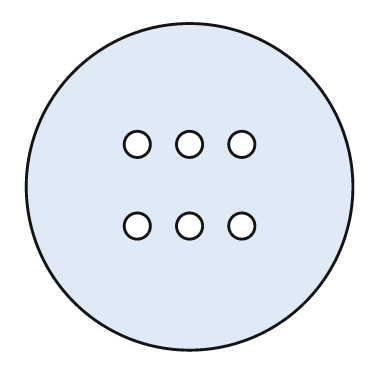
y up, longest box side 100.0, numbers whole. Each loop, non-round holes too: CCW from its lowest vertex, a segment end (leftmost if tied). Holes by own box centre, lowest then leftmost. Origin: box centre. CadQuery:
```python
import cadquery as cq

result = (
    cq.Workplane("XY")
    .moveTo(0.0, 0.0)
    .circle(50.0)
    .moveTo(-16.0, -12.0)
    .circle(4.0)
    .moveTo(0.0, -12.0)
    .circle(4.0)
    .moveTo(16.0, -12.0)
    .circle(4.0)
    .moveTo(-16.0, 13.0)
    .circle(4.0)
    .moveTo(0.0, 13.0)
    .circle(4.0)
    .moveTo(16.0, 13.0)
    .circle(4.0)
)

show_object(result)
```